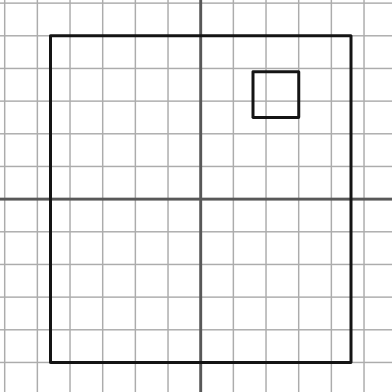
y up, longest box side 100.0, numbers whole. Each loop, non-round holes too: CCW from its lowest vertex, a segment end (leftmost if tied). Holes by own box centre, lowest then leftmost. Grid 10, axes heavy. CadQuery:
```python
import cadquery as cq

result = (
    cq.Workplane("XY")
    .moveTo(-46.0, -50.0)
    .lineTo(46.0, -50.0)
    .lineTo(46.0, 50.0)
    .lineTo(-46.0, 50.0)
    .close()
    .moveTo(16.0, 25.0)
    .lineTo(30.0, 25.0)
    .lineTo(30.0, 39.0)
    .lineTo(16.0, 39.0)
    .close()
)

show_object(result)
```